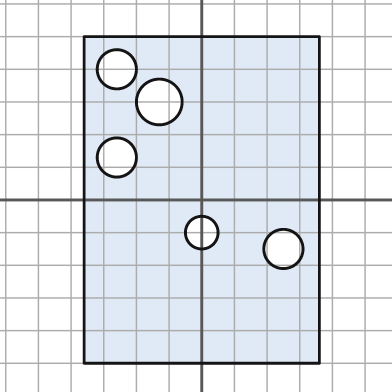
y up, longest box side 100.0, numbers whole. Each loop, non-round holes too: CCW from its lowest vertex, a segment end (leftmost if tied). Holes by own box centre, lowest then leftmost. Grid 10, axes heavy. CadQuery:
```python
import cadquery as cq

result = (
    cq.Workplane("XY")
    .moveTo(-36.0, -50.0)
    .lineTo(36.0, -50.0)
    .lineTo(36.0, 50.0)
    .lineTo(-36.0, 50.0)
    .close()
    .moveTo(25.0, -15.0)
    .circle(6.0)
    .moveTo(0.0, -10.0)
    .circle(5.0)
    .moveTo(-26.0, 13.0)
    .circle(6.0)
    .moveTo(-13.0, 30.0)
    .circle(7.0)
    .moveTo(-26.0, 40.0)
    .circle(6.0)
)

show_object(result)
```